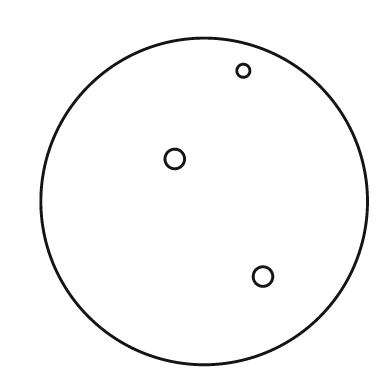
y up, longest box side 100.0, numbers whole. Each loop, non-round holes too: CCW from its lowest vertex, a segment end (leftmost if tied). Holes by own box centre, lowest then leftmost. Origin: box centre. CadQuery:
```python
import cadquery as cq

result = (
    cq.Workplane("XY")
    .moveTo(0.0, 0.0)
    .circle(50.0)
    .moveTo(18.0, -23.0)
    .circle(3.0)
    .moveTo(-9.0, 13.0)
    .circle(3.0)
    .moveTo(12.0, 40.0)
    .circle(2.0)
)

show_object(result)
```